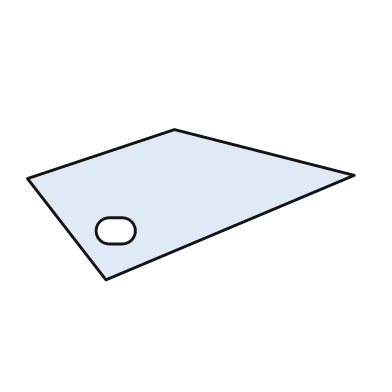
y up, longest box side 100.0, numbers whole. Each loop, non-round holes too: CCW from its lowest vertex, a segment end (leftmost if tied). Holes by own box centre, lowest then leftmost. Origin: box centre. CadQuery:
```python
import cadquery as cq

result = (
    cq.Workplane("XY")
    .moveTo(-26.0, -23.0)
    .lineTo(50.0, 9.0)
    .lineTo(-5.0, 23.0)
    .lineTo(-50.0, 8.0)
    .close()
    .moveTo(-25.0, -12.0)
    .lineTo(-21.0, -12.0)
    .threePointArc((-17.0, -8.0), (-21.0, -4.0))
    .lineTo(-25.0, -4.0)
    .threePointArc((-29.0, -8.0), (-25.0, -12.0))
    .close()
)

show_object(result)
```